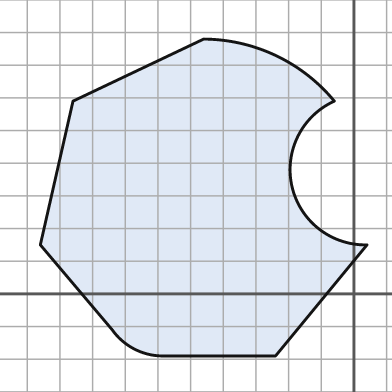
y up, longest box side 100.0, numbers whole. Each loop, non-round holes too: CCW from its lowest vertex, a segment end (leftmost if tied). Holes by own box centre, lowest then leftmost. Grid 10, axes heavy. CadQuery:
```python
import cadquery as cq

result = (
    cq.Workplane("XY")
    .moveTo(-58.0, -19.0)
    .lineTo(-24.0, -19.0)
    .lineTo(4.0, 15.0)
    .threePointArc((-19.0, 33.0), (-6.0, 59.0))
    .threePointArc((-24.0, 73.0), (-46.0, 78.0))
    .lineTo(-86.0, 59.0)
    .lineTo(-96.0, 15.0)
    .lineTo(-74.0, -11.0)
    .threePointArc((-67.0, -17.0), (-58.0, -19.0))
    .close()
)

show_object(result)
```